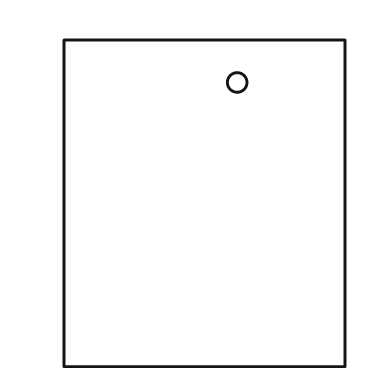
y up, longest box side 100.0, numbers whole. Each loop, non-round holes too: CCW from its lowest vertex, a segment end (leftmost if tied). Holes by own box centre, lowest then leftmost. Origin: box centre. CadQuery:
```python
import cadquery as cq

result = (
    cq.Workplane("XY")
    .moveTo(-43.0, -50.0)
    .lineTo(43.0, -50.0)
    .lineTo(43.0, 50.0)
    .lineTo(-43.0, 50.0)
    .close()
    .moveTo(10.0, 37.0)
    .circle(3.0)
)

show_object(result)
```